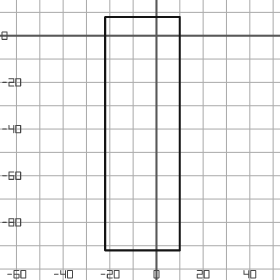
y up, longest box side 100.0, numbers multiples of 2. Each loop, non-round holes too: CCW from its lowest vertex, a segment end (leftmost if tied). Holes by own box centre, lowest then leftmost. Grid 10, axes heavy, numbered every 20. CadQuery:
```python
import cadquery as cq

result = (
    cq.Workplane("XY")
    .moveTo(-22.0, -92.0)
    .lineTo(10.0, -92.0)
    .lineTo(10.0, 8.0)
    .lineTo(-22.0, 8.0)
    .close()
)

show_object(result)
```